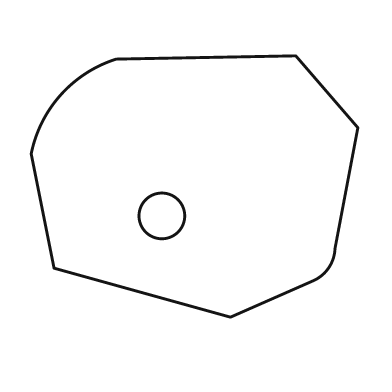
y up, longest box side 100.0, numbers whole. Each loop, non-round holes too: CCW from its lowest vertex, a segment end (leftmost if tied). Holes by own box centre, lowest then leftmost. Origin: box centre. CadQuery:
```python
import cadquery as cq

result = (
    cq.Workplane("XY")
    .moveTo(11.0, -40.0)
    .lineTo(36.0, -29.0)
    .threePointArc((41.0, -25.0), (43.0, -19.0))
    .lineTo(50.0, 18.0)
    .lineTo(31.0, 40.0)
    .lineTo(-24.0, 39.0)
    .threePointArc((-41.0, 28.0), (-50.0, 10.0))
    .lineTo(-43.0, -25.0)
    .close()
    .moveTo(-10.0, -9.0)
    .circle(7.0)
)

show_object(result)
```